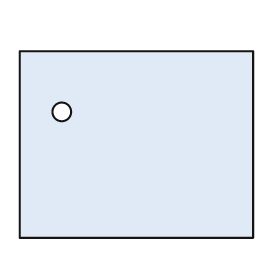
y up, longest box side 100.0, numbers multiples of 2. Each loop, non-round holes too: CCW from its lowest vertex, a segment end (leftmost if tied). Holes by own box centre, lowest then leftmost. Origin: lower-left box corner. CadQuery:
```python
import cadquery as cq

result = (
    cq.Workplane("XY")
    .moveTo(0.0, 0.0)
    .lineTo(100.0, 0.0)
    .lineTo(100.0, 80.0)
    .lineTo(0.0, 80.0)
    .close()
    .moveTo(18.0, 54.0)
    .circle(4.0)
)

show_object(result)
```